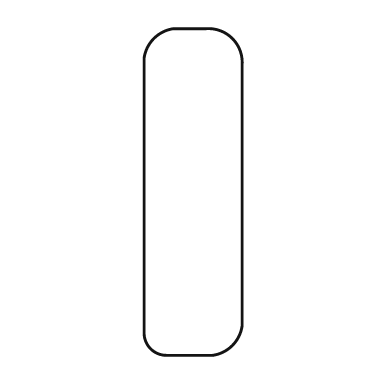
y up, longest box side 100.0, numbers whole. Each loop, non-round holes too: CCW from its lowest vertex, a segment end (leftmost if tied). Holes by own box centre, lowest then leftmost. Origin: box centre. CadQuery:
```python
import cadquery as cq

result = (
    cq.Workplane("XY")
    .moveTo(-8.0, -50.0)
    .lineTo(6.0, -50.0)
    .threePointArc((12.0, -47.0), (15.0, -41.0))
    .lineTo(15.0, 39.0)
    .threePointArc((12.0, 47.0), (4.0, 50.0))
    .lineTo(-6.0, 50.0)
    .threePointArc((-12.0, 47.0), (-15.0, 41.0))
    .lineTo(-15.0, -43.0)
    .threePointArc((-13.0, -48.0), (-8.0, -50.0))
    .close()
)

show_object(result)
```